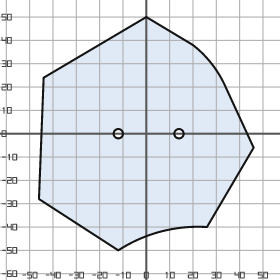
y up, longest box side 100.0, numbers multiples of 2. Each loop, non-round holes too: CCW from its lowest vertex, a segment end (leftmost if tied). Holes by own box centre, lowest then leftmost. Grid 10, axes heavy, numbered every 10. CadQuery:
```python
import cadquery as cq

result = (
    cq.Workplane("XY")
    .moveTo(-12.0, -50.0)
    .threePointArc((6.0, -42.0), (26.0, -40.0))
    .lineTo(46.0, -6.0)
    .lineTo(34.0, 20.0)
    .threePointArc((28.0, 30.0), (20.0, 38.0))
    .lineTo(0.0, 50.0)
    .lineTo(-44.0, 24.0)
    .lineTo(-46.0, -28.0)
    .close()
    .moveTo(-12.0, 0.0)
    .circle(2.0)
    .moveTo(14.0, 0.0)
    .circle(2.0)
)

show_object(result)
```